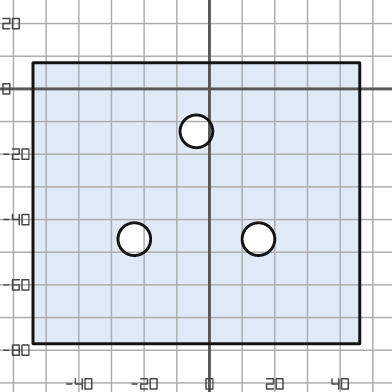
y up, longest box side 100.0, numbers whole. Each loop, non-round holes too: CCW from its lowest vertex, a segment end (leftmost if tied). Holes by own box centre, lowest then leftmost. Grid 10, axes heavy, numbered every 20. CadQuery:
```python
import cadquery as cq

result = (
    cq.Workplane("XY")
    .moveTo(-54.0, -78.0)
    .lineTo(46.0, -78.0)
    .lineTo(46.0, 8.0)
    .lineTo(-54.0, 8.0)
    .close()
    .moveTo(-23.0, -46.0)
    .circle(5.0)
    .moveTo(15.0, -46.0)
    .circle(5.0)
    .moveTo(-4.0, -13.0)
    .circle(5.0)
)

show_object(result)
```